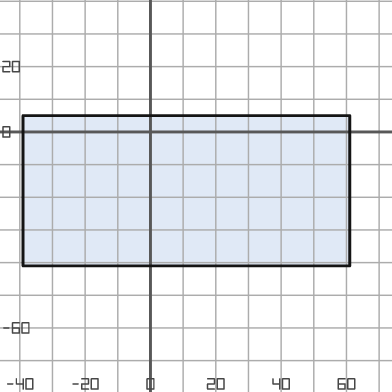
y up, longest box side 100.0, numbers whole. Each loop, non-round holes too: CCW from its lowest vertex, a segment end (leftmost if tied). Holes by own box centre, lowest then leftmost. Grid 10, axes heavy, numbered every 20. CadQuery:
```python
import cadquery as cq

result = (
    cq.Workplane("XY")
    .moveTo(-39.0, -41.0)
    .lineTo(61.0, -41.0)
    .lineTo(61.0, 5.0)
    .lineTo(-39.0, 5.0)
    .close()
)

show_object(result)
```